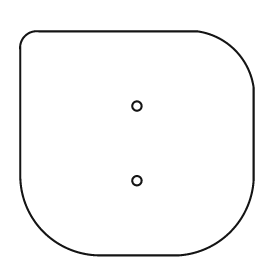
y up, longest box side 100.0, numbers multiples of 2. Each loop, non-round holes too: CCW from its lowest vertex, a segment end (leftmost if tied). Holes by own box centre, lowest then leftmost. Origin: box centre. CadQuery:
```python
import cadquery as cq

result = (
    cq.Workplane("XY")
    .moveTo(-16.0, -48.0)
    .lineTo(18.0, -48.0)
    .threePointArc((40.0, -38.0), (50.0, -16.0))
    .lineTo(50.0, 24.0)
    .threePointArc((42.0, 40.0), (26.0, 48.0))
    .lineTo(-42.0, 48.0)
    .threePointArc((-48.0, 46.0), (-50.0, 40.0))
    .lineTo(-50.0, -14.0)
    .threePointArc((-40.0, -38.0), (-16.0, -48.0))
    .close()
    .moveTo(0.0, -16.0)
    .circle(2.0)
    .moveTo(0.0, 16.0)
    .circle(2.0)
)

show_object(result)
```